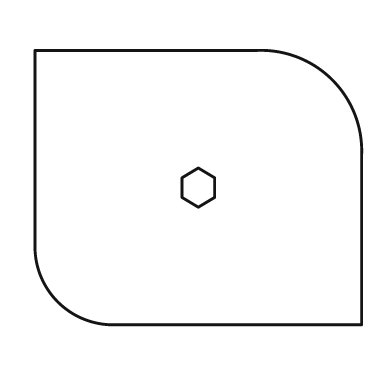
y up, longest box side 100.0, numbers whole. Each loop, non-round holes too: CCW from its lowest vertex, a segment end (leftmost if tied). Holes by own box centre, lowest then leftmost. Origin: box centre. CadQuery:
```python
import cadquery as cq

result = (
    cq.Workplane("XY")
    .moveTo(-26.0, -42.0)
    .lineTo(50.0, -42.0)
    .lineTo(50.0, 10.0)
    .threePointArc((41.0, 33.0), (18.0, 42.0))
    .lineTo(-50.0, 42.0)
    .lineTo(-50.0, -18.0)
    .threePointArc((-43.0, -35.0), (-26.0, -42.0))
    .close()
    .moveTo(0.0, -6.0)
    .lineTo(5.0, -3.0)
    .lineTo(5.0, 3.0)
    .lineTo(0.0, 6.0)
    .lineTo(-5.0, 3.0)
    .lineTo(-5.0, -3.0)
    .close()
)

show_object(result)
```